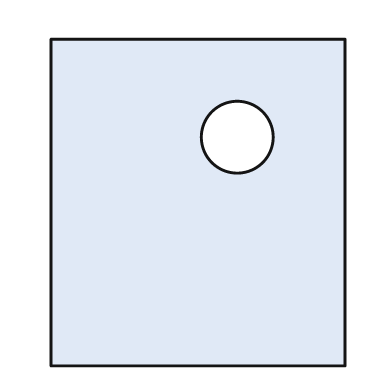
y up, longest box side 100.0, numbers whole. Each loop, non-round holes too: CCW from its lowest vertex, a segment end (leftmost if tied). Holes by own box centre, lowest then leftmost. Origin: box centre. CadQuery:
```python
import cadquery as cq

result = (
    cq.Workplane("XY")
    .moveTo(-45.0, -50.0)
    .lineTo(45.0, -50.0)
    .lineTo(45.0, 50.0)
    .lineTo(-45.0, 50.0)
    .close()
    .moveTo(12.0, 20.0)
    .circle(11.0)
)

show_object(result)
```